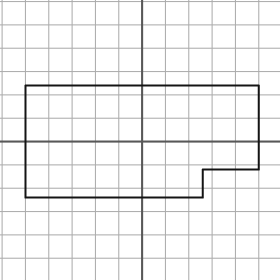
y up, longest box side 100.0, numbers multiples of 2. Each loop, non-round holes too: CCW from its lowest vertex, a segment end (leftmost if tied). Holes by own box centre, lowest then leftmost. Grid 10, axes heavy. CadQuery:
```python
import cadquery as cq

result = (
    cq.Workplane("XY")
    .moveTo(-50.0, -24.0)
    .lineTo(26.0, -24.0)
    .lineTo(26.0, -12.0)
    .lineTo(50.0, -12.0)
    .lineTo(50.0, 24.0)
    .lineTo(-50.0, 24.0)
    .close()
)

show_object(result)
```